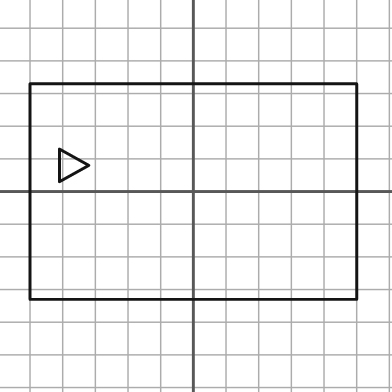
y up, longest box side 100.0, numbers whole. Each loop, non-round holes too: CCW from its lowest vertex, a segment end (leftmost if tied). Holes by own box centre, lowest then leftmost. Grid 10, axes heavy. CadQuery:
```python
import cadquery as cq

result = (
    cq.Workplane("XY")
    .moveTo(-50.0, -33.0)
    .lineTo(50.0, -33.0)
    .lineTo(50.0, 33.0)
    .lineTo(-50.0, 33.0)
    .close()
    .moveTo(-41.0, 3.0)
    .lineTo(-32.0, 8.0)
    .lineTo(-41.0, 13.0)
    .close()
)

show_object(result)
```